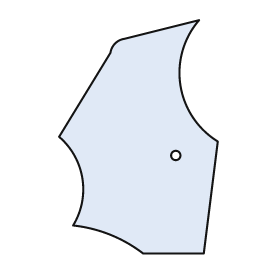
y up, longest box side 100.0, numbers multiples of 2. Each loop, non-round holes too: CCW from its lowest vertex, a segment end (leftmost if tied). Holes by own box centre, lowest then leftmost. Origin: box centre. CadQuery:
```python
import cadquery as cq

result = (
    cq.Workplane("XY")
    .moveTo(2.0, -50.0)
    .lineTo(28.0, -50.0)
    .lineTo(34.0, -2.0)
    .threePointArc((18.0, 22.0), (26.0, 50.0))
    .lineTo(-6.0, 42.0)
    .threePointArc((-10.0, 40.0), (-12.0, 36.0))
    .lineTo(-34.0, 0.0)
    .threePointArc((-24.0, -18.0), (-28.0, -38.0))
    .threePointArc((-12.0, -42.0), (2.0, -50.0))
    .close()
    .moveTo(16.0, -8.0)
    .circle(2.0)
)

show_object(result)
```